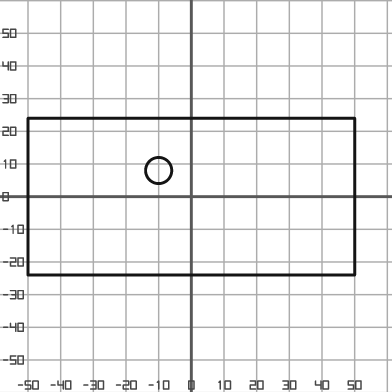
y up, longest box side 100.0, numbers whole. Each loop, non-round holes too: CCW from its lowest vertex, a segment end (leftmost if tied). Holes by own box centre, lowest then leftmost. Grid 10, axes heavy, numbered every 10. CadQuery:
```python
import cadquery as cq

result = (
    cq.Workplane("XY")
    .moveTo(-50.0, -24.0)
    .lineTo(50.0, -24.0)
    .lineTo(50.0, 24.0)
    .lineTo(-50.0, 24.0)
    .close()
    .moveTo(-10.0, 8.0)
    .circle(4.0)
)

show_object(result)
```